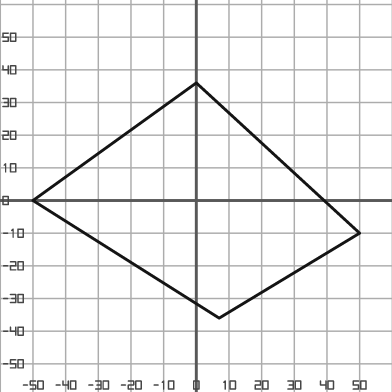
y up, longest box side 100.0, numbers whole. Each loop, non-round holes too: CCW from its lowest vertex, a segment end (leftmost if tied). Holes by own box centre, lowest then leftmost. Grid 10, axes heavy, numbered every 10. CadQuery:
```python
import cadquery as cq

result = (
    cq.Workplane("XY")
    .moveTo(7.0, -36.0)
    .lineTo(50.0, -10.0)
    .lineTo(0.0, 36.0)
    .lineTo(-50.0, 0.0)
    .close()
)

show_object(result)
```